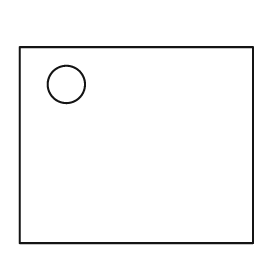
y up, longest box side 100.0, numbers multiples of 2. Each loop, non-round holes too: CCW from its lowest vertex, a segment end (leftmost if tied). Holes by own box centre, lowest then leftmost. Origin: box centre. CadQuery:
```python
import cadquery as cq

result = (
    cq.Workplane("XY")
    .moveTo(-50.0, -42.0)
    .lineTo(50.0, -42.0)
    .lineTo(50.0, 42.0)
    .lineTo(-50.0, 42.0)
    .close()
    .moveTo(-30.0, 26.0)
    .circle(8.0)
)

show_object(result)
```